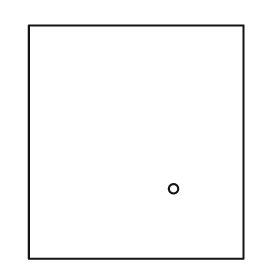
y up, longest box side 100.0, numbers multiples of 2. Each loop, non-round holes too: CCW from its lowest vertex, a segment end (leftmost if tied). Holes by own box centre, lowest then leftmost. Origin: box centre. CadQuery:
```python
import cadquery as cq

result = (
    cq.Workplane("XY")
    .moveTo(-46.0, -50.0)
    .lineTo(46.0, -50.0)
    .lineTo(46.0, 50.0)
    .lineTo(-46.0, 50.0)
    .close()
    .moveTo(16.0, -20.0)
    .circle(2.0)
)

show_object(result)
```